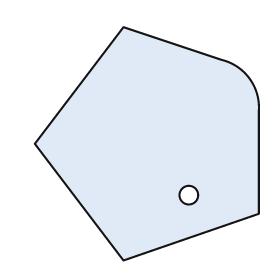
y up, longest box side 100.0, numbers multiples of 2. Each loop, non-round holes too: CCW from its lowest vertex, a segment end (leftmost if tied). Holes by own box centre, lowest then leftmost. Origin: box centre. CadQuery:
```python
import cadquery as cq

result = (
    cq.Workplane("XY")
    .moveTo(-10.0, -50.0)
    .lineTo(48.0, -30.0)
    .lineTo(48.0, 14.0)
    .threePointArc((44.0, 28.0), (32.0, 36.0))
    .lineTo(-10.0, 50.0)
    .lineTo(-48.0, 0.0)
    .close()
    .moveTo(18.0, -22.0)
    .circle(4.0)
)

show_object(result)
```